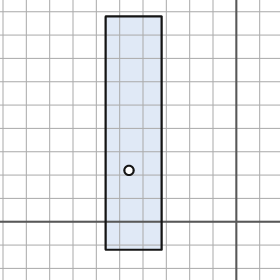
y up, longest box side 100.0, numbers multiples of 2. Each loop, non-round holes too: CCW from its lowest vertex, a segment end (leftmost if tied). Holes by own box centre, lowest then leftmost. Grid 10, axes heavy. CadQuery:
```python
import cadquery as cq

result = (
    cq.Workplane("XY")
    .moveTo(-56.0, -12.0)
    .lineTo(-32.0, -12.0)
    .lineTo(-32.0, 88.0)
    .lineTo(-56.0, 88.0)
    .close()
    .moveTo(-46.0, 22.0)
    .circle(2.0)
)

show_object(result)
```